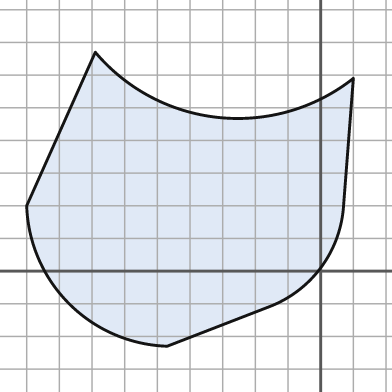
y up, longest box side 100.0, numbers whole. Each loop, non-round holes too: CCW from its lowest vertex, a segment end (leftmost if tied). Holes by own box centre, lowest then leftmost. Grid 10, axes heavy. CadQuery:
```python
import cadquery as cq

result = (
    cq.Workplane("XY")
    .moveTo(-47.0, -23.0)
    .lineTo(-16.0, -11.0)
    .threePointArc((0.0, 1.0), (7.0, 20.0))
    .lineTo(10.0, 59.0)
    .threePointArc((-31.0, 47.0), (-69.0, 67.0))
    .lineTo(-90.0, 20.0)
    .threePointArc((-77.0, -10.0), (-47.0, -23.0))
    .close()
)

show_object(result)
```